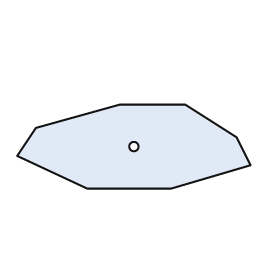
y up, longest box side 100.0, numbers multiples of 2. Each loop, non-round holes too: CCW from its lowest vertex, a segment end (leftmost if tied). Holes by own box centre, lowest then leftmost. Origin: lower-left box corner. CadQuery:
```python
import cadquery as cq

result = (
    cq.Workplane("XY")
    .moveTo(30.0, 0.0)
    .lineTo(66.0, 0.0)
    .lineTo(100.0, 10.0)
    .lineTo(94.0, 22.0)
    .lineTo(72.0, 36.0)
    .lineTo(44.0, 36.0)
    .lineTo(8.0, 26.0)
    .lineTo(0.0, 14.0)
    .close()
    .moveTo(50.0, 18.0)
    .circle(2.0)
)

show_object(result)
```